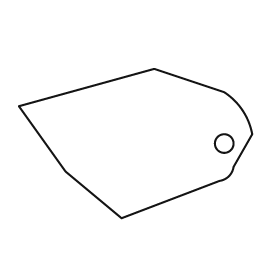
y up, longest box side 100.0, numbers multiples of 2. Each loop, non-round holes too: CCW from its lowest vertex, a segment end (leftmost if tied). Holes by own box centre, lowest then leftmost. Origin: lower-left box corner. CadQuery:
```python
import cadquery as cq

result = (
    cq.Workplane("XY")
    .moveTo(44.0, 0.0)
    .lineTo(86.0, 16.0)
    .threePointArc((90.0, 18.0), (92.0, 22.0))
    .lineTo(100.0, 36.0)
    .threePointArc((96.0, 46.0), (88.0, 54.0))
    .lineTo(58.0, 64.0)
    .lineTo(0.0, 48.0)
    .lineTo(20.0, 20.0)
    .close()
    .moveTo(88.0, 32.0)
    .circle(4.0)
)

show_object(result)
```